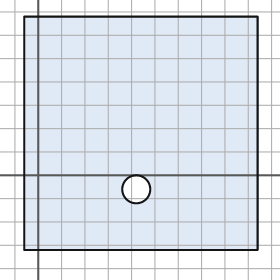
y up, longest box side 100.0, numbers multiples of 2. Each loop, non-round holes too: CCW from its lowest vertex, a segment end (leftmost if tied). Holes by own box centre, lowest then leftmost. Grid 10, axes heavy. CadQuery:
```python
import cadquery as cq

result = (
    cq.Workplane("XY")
    .moveTo(-6.0, -32.0)
    .lineTo(94.0, -32.0)
    .lineTo(94.0, 68.0)
    .lineTo(-6.0, 68.0)
    .close()
    .moveTo(42.0, -6.0)
    .circle(6.0)
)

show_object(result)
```